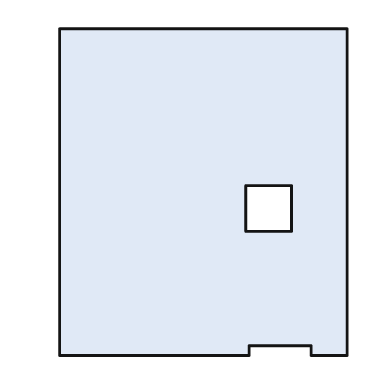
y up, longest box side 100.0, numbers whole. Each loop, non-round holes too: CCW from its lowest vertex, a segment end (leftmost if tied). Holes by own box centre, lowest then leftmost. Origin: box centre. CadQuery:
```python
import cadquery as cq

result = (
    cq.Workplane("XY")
    .moveTo(-44.0, -50.0)
    .lineTo(14.0, -50.0)
    .lineTo(14.0, -47.0)
    .lineTo(33.0, -47.0)
    .lineTo(33.0, -50.0)
    .lineTo(44.0, -50.0)
    .lineTo(44.0, 50.0)
    .lineTo(-44.0, 50.0)
    .close()
    .moveTo(13.0, -12.0)
    .lineTo(27.0, -12.0)
    .lineTo(27.0, 2.0)
    .lineTo(13.0, 2.0)
    .close()
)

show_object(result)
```